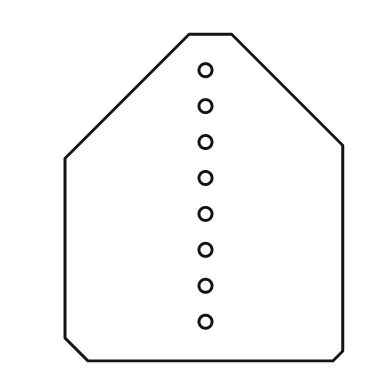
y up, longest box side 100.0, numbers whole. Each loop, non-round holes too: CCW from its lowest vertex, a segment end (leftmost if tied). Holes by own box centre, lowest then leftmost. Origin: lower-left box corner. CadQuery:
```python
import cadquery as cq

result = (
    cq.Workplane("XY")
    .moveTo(7.0, 0.0)
    .lineTo(82.0, 0.0)
    .lineTo(85.0, 3.0)
    .lineTo(85.0, 66.0)
    .lineTo(51.0, 100.0)
    .lineTo(38.0, 100.0)
    .lineTo(0.0, 62.0)
    .lineTo(0.0, 7.0)
    .close()
    .moveTo(43.0, 12.0)
    .circle(2.0)
    .moveTo(43.0, 23.0)
    .circle(2.0)
    .moveTo(43.0, 34.0)
    .circle(2.0)
    .moveTo(43.0, 45.0)
    .circle(2.0)
    .moveTo(43.0, 56.0)
    .circle(2.0)
    .moveTo(43.0, 67.0)
    .circle(2.0)
    .moveTo(43.0, 78.0)
    .circle(2.0)
    .moveTo(43.0, 89.0)
    .circle(2.0)
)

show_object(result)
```